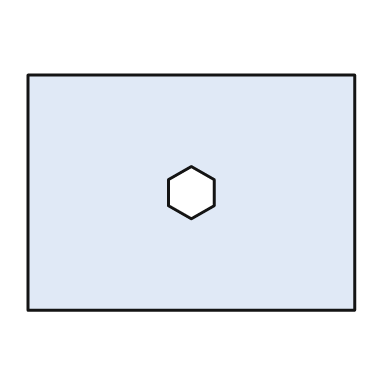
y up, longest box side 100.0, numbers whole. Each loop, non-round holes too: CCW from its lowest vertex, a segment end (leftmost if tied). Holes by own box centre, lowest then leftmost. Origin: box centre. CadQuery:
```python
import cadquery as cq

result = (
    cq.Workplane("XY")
    .moveTo(-50.0, -36.0)
    .lineTo(50.0, -36.0)
    .lineTo(50.0, 36.0)
    .lineTo(-50.0, 36.0)
    .close()
    .moveTo(0.0, -8.0)
    .lineTo(7.0, -4.0)
    .lineTo(7.0, 4.0)
    .lineTo(0.0, 8.0)
    .lineTo(-7.0, 4.0)
    .lineTo(-7.0, -4.0)
    .close()
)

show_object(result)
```